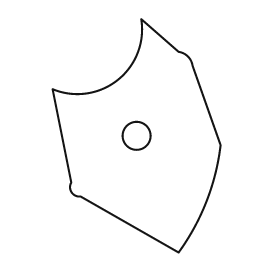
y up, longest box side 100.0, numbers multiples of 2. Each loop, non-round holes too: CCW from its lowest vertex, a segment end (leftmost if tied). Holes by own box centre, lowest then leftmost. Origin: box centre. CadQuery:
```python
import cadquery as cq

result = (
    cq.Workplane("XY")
    .moveTo(18.0, -50.0)
    .threePointArc((30.0, -28.0), (36.0, -4.0))
    .lineTo(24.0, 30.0)
    .threePointArc((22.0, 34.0), (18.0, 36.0))
    .lineTo(2.0, 50.0)
    .threePointArc((-8.0, 24.0), (-36.0, 20.0))
    .lineTo(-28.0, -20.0)
    .threePointArc((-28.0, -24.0), (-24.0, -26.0))
    .close()
    .moveTo(0.0, 0.0)
    .circle(6.0)
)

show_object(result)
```